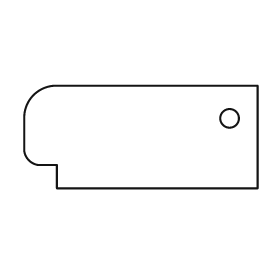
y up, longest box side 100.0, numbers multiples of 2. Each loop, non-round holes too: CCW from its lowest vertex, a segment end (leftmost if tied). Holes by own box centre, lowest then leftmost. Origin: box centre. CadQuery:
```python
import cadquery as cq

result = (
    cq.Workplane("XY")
    .moveTo(-36.0, -22.0)
    .lineTo(50.0, -22.0)
    .lineTo(50.0, 22.0)
    .lineTo(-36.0, 22.0)
    .threePointArc((-46.0, 18.0), (-50.0, 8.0))
    .lineTo(-50.0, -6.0)
    .threePointArc((-48.0, -10.0), (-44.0, -12.0))
    .lineTo(-36.0, -12.0)
    .close()
    .moveTo(38.0, 8.0)
    .circle(4.0)
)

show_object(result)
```